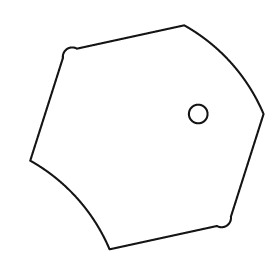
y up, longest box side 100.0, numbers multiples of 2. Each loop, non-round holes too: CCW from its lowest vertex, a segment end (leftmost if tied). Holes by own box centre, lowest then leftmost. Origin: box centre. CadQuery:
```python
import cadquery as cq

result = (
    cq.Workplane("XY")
    .moveTo(-16.0, -48.0)
    .lineTo(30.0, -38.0)
    .threePointArc((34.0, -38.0), (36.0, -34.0))
    .lineTo(50.0, 10.0)
    .threePointArc((36.0, 32.0), (16.0, 48.0))
    .lineTo(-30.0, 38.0)
    .threePointArc((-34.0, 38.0), (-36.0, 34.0))
    .lineTo(-50.0, -10.0)
    .threePointArc((-30.0, -26.0), (-16.0, -48.0))
    .close()
    .moveTo(22.0, 10.0)
    .circle(4.0)
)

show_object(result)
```